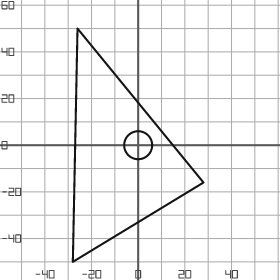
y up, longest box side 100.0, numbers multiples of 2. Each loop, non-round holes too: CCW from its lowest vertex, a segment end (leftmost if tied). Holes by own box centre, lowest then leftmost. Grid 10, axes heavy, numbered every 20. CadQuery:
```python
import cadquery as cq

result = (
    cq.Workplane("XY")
    .moveTo(-28.0, -50.0)
    .lineTo(28.0, -16.0)
    .lineTo(-26.0, 50.0)
    .close()
    .moveTo(0.0, 0.0)
    .circle(6.0)
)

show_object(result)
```